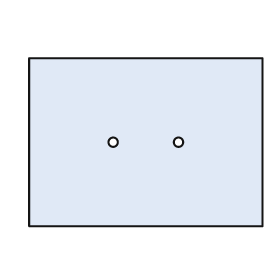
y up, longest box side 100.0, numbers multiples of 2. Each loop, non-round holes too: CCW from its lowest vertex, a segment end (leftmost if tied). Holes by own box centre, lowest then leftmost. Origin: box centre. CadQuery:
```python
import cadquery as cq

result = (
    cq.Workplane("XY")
    .moveTo(-50.0, -36.0)
    .lineTo(50.0, -36.0)
    .lineTo(50.0, 36.0)
    .lineTo(-50.0, 36.0)
    .close()
    .moveTo(-14.0, 0.0)
    .circle(2.0)
    .moveTo(14.0, 0.0)
    .circle(2.0)
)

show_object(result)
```